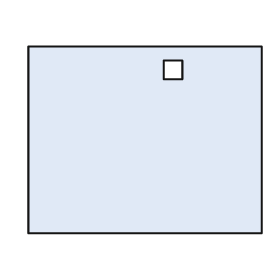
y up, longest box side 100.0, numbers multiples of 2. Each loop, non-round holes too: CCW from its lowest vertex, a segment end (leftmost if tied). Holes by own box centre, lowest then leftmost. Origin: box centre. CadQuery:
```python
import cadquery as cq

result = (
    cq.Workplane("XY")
    .moveTo(-50.0, -40.0)
    .lineTo(50.0, -40.0)
    .lineTo(50.0, 40.0)
    .lineTo(-50.0, 40.0)
    .close()
    .moveTo(8.0, 26.0)
    .lineTo(16.0, 26.0)
    .lineTo(16.0, 34.0)
    .lineTo(8.0, 34.0)
    .close()
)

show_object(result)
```